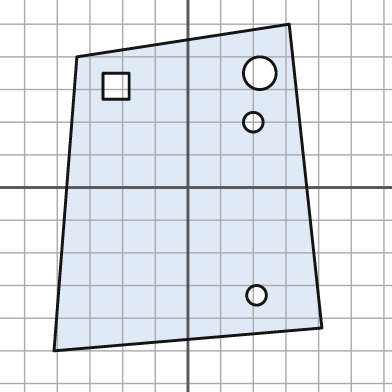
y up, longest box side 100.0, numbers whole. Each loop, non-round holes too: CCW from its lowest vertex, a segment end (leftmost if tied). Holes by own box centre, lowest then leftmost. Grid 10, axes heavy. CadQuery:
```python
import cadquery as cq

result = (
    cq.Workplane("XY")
    .moveTo(-41.0, -50.0)
    .lineTo(41.0, -43.0)
    .lineTo(31.0, 50.0)
    .lineTo(-34.0, 40.0)
    .close()
    .moveTo(21.0, -33.0)
    .circle(3.0)
    .moveTo(20.0, 20.0)
    .circle(3.0)
    .moveTo(-26.0, 27.0)
    .lineTo(-18.0, 27.0)
    .lineTo(-18.0, 35.0)
    .lineTo(-26.0, 35.0)
    .close()
    .moveTo(22.0, 35.0)
    .circle(5.0)
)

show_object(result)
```